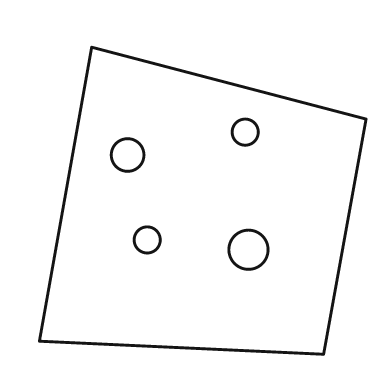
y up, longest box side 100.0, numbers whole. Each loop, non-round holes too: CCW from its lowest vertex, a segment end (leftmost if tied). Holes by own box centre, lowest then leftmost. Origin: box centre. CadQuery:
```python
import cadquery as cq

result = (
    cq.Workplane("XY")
    .moveTo(37.0, -47.0)
    .lineTo(50.0, 25.0)
    .lineTo(-34.0, 47.0)
    .lineTo(-50.0, -43.0)
    .close()
    .moveTo(14.0, -15.0)
    .circle(6.0)
    .moveTo(-17.0, -12.0)
    .circle(4.0)
    .moveTo(-23.0, 14.0)
    .circle(5.0)
    .moveTo(13.0, 21.0)
    .circle(4.0)
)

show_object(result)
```